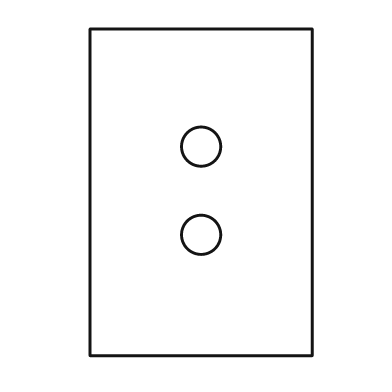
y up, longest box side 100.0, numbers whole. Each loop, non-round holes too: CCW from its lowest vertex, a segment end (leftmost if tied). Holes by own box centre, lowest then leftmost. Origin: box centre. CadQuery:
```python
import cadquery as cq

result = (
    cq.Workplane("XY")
    .moveTo(-34.0, -50.0)
    .lineTo(34.0, -50.0)
    .lineTo(34.0, 50.0)
    .lineTo(-34.0, 50.0)
    .close()
    .moveTo(0.0, -13.0)
    .circle(6.0)
    .moveTo(0.0, 14.0)
    .circle(6.0)
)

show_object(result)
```